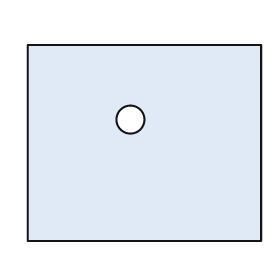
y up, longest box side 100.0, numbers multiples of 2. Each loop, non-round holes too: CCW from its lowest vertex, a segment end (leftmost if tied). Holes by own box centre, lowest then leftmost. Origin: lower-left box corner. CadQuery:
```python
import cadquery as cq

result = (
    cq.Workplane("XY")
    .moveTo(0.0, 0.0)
    .lineTo(100.0, 0.0)
    .lineTo(100.0, 84.0)
    .lineTo(0.0, 84.0)
    .close()
    .moveTo(44.0, 52.0)
    .circle(6.0)
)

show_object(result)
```